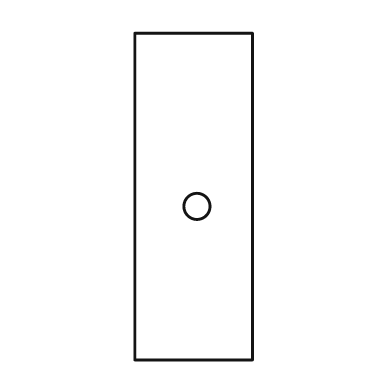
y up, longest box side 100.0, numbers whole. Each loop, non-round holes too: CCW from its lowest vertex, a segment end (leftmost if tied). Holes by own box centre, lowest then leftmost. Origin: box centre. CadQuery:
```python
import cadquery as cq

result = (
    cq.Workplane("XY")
    .moveTo(-18.0, -50.0)
    .lineTo(18.0, -50.0)
    .lineTo(18.0, 50.0)
    .lineTo(-18.0, 50.0)
    .close()
    .moveTo(1.0, -3.0)
    .circle(4.0)
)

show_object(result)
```